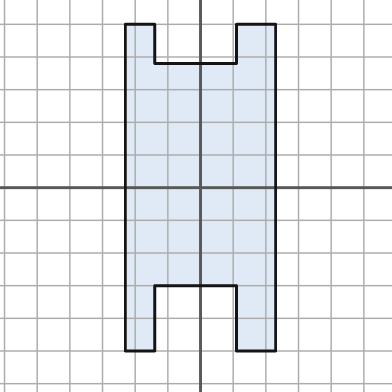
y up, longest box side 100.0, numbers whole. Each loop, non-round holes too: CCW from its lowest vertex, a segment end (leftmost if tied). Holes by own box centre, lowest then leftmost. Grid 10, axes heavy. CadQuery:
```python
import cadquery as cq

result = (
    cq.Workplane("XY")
    .moveTo(-23.0, -50.0)
    .lineTo(-14.0, -50.0)
    .lineTo(-14.0, -30.0)
    .lineTo(11.0, -30.0)
    .lineTo(11.0, -50.0)
    .lineTo(23.0, -50.0)
    .lineTo(23.0, 50.0)
    .lineTo(11.0, 50.0)
    .lineTo(11.0, 38.0)
    .lineTo(-14.0, 38.0)
    .lineTo(-14.0, 50.0)
    .lineTo(-23.0, 50.0)
    .close()
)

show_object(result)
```